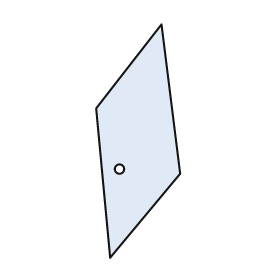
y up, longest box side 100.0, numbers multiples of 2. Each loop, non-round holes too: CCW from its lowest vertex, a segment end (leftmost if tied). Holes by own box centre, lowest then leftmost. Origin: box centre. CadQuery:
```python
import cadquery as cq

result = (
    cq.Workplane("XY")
    .moveTo(-12.0, -50.0)
    .lineTo(18.0, -14.0)
    .lineTo(10.0, 50.0)
    .lineTo(-18.0, 14.0)
    .close()
    .moveTo(-8.0, -12.0)
    .circle(2.0)
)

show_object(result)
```